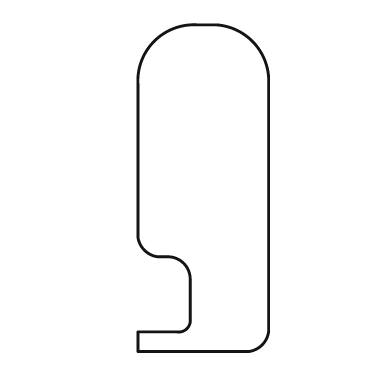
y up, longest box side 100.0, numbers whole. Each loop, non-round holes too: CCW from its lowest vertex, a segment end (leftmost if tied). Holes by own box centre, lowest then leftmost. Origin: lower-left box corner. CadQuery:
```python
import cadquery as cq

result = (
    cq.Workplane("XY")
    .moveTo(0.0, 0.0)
    .lineTo(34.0, 0.0)
    .threePointArc((38.0, 2.0), (40.0, 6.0))
    .lineTo(40.0, 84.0)
    .threePointArc((35.0, 95.0), (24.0, 100.0))
    .lineTo(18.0, 100.0)
    .threePointArc((5.0, 95.0), (0.0, 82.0))
    .lineTo(0.0, 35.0)
    .threePointArc((2.0, 31.0), (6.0, 29.0))
    .lineTo(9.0, 29.0)
    .threePointArc((14.0, 27.0), (16.0, 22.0))
    .lineTo(16.0, 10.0)
    .threePointArc((15.0, 7.0), (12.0, 6.0))
    .lineTo(0.0, 6.0)
    .close()
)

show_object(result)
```